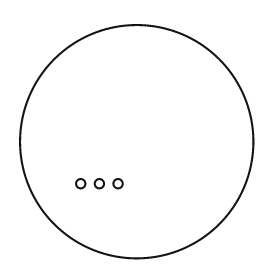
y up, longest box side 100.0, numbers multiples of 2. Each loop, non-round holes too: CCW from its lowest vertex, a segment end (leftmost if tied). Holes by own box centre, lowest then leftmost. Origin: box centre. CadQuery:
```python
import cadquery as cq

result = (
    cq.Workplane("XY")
    .moveTo(0.0, 0.0)
    .circle(50.0)
    .moveTo(-24.0, -18.0)
    .circle(2.0)
    .moveTo(-16.0, -18.0)
    .circle(2.0)
    .moveTo(-8.0, -18.0)
    .circle(2.0)
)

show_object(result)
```